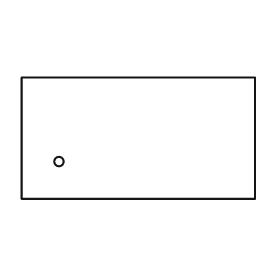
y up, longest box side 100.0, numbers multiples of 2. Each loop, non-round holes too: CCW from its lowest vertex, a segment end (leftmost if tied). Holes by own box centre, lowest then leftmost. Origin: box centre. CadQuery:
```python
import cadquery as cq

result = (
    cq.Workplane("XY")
    .moveTo(-50.0, -26.0)
    .lineTo(50.0, -26.0)
    .lineTo(50.0, 26.0)
    .lineTo(-50.0, 26.0)
    .close()
    .moveTo(-34.0, -10.0)
    .circle(2.0)
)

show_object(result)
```